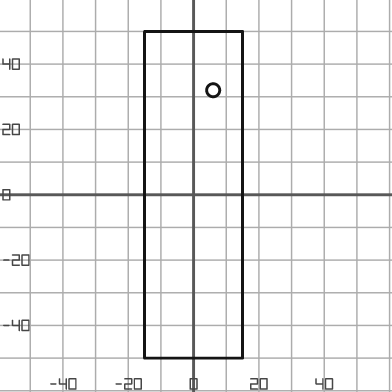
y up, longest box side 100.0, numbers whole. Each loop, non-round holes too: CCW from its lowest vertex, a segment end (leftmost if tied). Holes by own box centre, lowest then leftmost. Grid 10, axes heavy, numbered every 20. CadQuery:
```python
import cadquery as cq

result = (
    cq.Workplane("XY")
    .moveTo(-15.0, -50.0)
    .lineTo(15.0, -50.0)
    .lineTo(15.0, 50.0)
    .lineTo(-15.0, 50.0)
    .close()
    .moveTo(6.0, 32.0)
    .circle(2.0)
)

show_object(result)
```